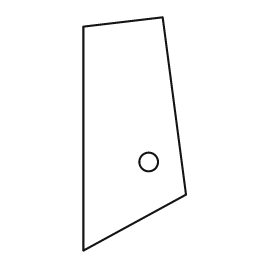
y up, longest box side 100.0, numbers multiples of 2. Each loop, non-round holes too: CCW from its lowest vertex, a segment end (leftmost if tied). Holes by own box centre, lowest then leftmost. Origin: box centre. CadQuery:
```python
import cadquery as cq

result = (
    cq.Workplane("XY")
    .moveTo(-22.0, -50.0)
    .lineTo(22.0, -26.0)
    .lineTo(12.0, 50.0)
    .lineTo(-22.0, 46.0)
    .close()
    .moveTo(6.0, -12.0)
    .circle(4.0)
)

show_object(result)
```